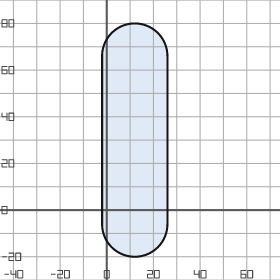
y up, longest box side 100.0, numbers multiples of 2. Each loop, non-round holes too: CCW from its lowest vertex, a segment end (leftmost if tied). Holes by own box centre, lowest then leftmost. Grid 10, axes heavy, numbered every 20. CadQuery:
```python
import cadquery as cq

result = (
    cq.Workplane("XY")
    .moveTo(-2.0, -6.0)
    .threePointArc((12.0, -20.0), (26.0, -6.0))
    .lineTo(26.0, 66.0)
    .threePointArc((12.0, 80.0), (-2.0, 66.0))
    .close()
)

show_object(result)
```